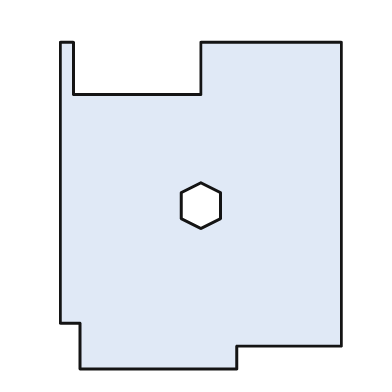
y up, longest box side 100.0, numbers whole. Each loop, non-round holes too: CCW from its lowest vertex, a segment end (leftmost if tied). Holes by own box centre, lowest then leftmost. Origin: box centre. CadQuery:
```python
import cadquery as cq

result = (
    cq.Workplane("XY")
    .moveTo(-37.0, -50.0)
    .lineTo(11.0, -50.0)
    .lineTo(11.0, -43.0)
    .lineTo(43.0, -43.0)
    .lineTo(43.0, 50.0)
    .lineTo(0.0, 50.0)
    .lineTo(0.0, 34.0)
    .lineTo(-39.0, 34.0)
    .lineTo(-39.0, 50.0)
    .lineTo(-43.0, 50.0)
    .lineTo(-43.0, -36.0)
    .lineTo(-37.0, -36.0)
    .close()
    .moveTo(0.0, -7.0)
    .lineTo(6.0, -4.0)
    .lineTo(6.0, 4.0)
    .lineTo(0.0, 7.0)
    .lineTo(-6.0, 4.0)
    .lineTo(-6.0, -4.0)
    .close()
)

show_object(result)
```